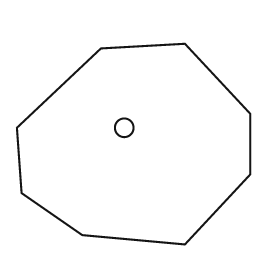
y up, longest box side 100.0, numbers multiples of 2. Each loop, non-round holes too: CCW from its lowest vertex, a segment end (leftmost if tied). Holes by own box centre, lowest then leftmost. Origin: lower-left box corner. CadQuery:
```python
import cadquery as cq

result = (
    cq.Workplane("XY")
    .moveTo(72.0, 0.0)
    .lineTo(100.0, 30.0)
    .lineTo(100.0, 56.0)
    .lineTo(72.0, 86.0)
    .lineTo(36.0, 84.0)
    .lineTo(0.0, 50.0)
    .lineTo(2.0, 22.0)
    .lineTo(28.0, 4.0)
    .close()
    .moveTo(46.0, 50.0)
    .circle(4.0)
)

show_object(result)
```